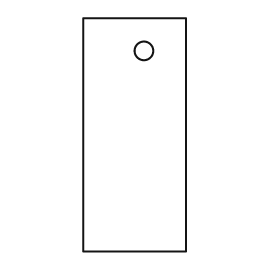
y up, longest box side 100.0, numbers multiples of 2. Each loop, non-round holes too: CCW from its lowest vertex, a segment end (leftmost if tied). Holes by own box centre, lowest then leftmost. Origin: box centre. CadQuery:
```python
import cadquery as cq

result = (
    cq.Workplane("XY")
    .moveTo(-22.0, -50.0)
    .lineTo(22.0, -50.0)
    .lineTo(22.0, 50.0)
    .lineTo(-22.0, 50.0)
    .close()
    .moveTo(4.0, 36.0)
    .circle(4.0)
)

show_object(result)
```